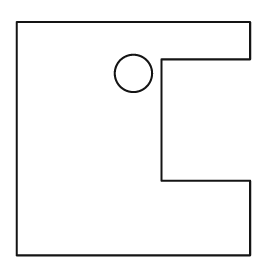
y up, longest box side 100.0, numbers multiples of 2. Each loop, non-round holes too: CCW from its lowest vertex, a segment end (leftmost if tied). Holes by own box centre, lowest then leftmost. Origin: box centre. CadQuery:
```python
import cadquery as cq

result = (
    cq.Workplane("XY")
    .moveTo(-50.0, -50.0)
    .lineTo(50.0, -50.0)
    .lineTo(50.0, -18.0)
    .lineTo(12.0, -18.0)
    .lineTo(12.0, 34.0)
    .lineTo(50.0, 34.0)
    .lineTo(50.0, 50.0)
    .lineTo(-50.0, 50.0)
    .close()
    .moveTo(0.0, 28.0)
    .circle(8.0)
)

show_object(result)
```